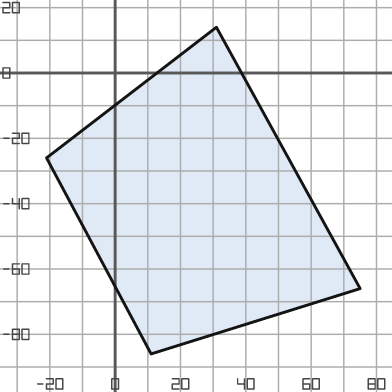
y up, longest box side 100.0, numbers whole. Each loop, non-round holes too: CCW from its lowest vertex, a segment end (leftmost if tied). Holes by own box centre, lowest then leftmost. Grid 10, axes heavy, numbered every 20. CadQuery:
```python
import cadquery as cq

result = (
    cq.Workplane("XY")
    .moveTo(11.0, -86.0)
    .lineTo(75.0, -66.0)
    .lineTo(31.0, 14.0)
    .lineTo(-21.0, -26.0)
    .close()
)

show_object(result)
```